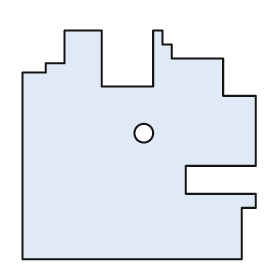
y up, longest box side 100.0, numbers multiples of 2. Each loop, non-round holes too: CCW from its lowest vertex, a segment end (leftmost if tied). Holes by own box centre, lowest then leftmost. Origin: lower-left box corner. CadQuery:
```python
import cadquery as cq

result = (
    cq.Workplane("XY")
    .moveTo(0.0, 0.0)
    .lineTo(94.0, 0.0)
    .lineTo(94.0, 22.0)
    .lineTo(100.0, 22.0)
    .lineTo(100.0, 28.0)
    .lineTo(70.0, 28.0)
    .lineTo(70.0, 40.0)
    .lineTo(100.0, 40.0)
    .lineTo(100.0, 70.0)
    .lineTo(86.0, 70.0)
    .lineTo(86.0, 86.0)
    .lineTo(64.0, 86.0)
    .lineTo(64.0, 92.0)
    .lineTo(60.0, 92.0)
    .lineTo(60.0, 98.0)
    .lineTo(56.0, 98.0)
    .lineTo(56.0, 74.0)
    .lineTo(34.0, 74.0)
    .lineTo(34.0, 98.0)
    .lineTo(18.0, 98.0)
    .lineTo(18.0, 84.0)
    .lineTo(10.0, 84.0)
    .lineTo(10.0, 80.0)
    .lineTo(0.0, 80.0)
    .close()
    .moveTo(52.0, 54.0)
    .circle(4.0)
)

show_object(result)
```